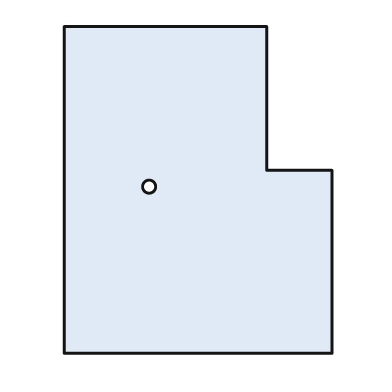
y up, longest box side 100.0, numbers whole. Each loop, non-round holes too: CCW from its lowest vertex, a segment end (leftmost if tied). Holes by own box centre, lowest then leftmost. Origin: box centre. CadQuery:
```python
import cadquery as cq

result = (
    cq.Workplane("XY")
    .moveTo(-41.0, -50.0)
    .lineTo(41.0, -50.0)
    .lineTo(41.0, 6.0)
    .lineTo(21.0, 6.0)
    .lineTo(21.0, 50.0)
    .lineTo(-41.0, 50.0)
    .close()
    .moveTo(-15.0, 1.0)
    .circle(2.0)
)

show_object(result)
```